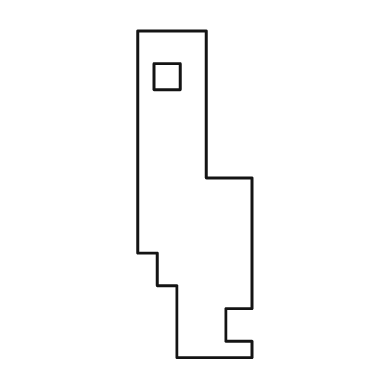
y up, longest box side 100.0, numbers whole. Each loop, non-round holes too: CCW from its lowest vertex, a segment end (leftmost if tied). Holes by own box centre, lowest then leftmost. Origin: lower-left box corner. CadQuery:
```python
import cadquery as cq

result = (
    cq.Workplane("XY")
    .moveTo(12.0, 0.0)
    .lineTo(35.0, 0.0)
    .lineTo(35.0, 5.0)
    .lineTo(27.0, 5.0)
    .lineTo(27.0, 15.0)
    .lineTo(35.0, 15.0)
    .lineTo(35.0, 55.0)
    .lineTo(21.0, 55.0)
    .lineTo(21.0, 100.0)
    .lineTo(0.0, 100.0)
    .lineTo(0.0, 32.0)
    .lineTo(6.0, 32.0)
    .lineTo(6.0, 22.0)
    .lineTo(12.0, 22.0)
    .close()
    .moveTo(5.0, 82.0)
    .lineTo(13.0, 82.0)
    .lineTo(13.0, 90.0)
    .lineTo(5.0, 90.0)
    .close()
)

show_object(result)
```